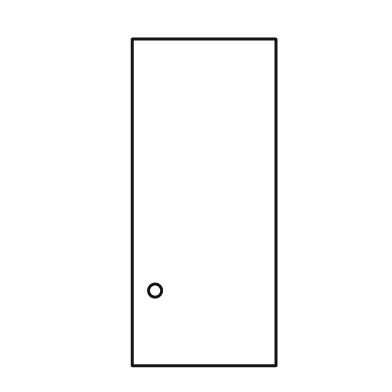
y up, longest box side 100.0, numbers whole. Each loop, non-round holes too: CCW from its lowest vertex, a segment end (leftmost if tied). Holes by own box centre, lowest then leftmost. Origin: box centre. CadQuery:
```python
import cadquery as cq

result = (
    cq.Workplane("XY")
    .moveTo(-22.0, -50.0)
    .lineTo(22.0, -50.0)
    .lineTo(22.0, 50.0)
    .lineTo(-22.0, 50.0)
    .close()
    .moveTo(-15.0, -27.0)
    .circle(2.0)
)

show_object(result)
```